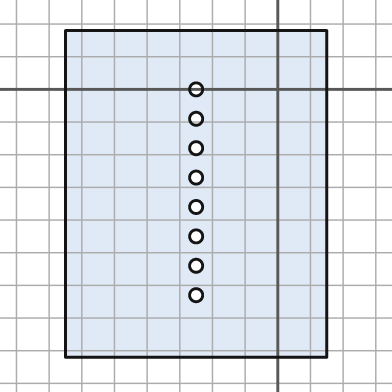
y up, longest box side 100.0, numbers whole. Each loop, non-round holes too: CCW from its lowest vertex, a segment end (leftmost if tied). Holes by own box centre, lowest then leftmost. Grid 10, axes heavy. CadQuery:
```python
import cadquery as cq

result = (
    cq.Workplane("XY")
    .moveTo(-65.0, -82.0)
    .lineTo(15.0, -82.0)
    .lineTo(15.0, 18.0)
    .lineTo(-65.0, 18.0)
    .close()
    .moveTo(-25.0, -63.0)
    .circle(2.0)
    .moveTo(-25.0, -54.0)
    .circle(2.0)
    .moveTo(-25.0, -45.0)
    .circle(2.0)
    .moveTo(-25.0, -36.0)
    .circle(2.0)
    .moveTo(-25.0, -27.0)
    .circle(2.0)
    .moveTo(-25.0, -18.0)
    .circle(2.0)
    .moveTo(-25.0, -9.0)
    .circle(2.0)
    .moveTo(-25.0, 0.0)
    .circle(2.0)
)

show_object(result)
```